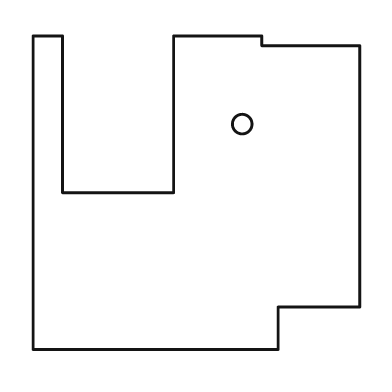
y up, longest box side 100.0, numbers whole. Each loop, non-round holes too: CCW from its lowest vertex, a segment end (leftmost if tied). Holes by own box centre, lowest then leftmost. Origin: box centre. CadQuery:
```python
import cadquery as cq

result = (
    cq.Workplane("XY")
    .moveTo(-50.0, -48.0)
    .lineTo(25.0, -48.0)
    .lineTo(25.0, -35.0)
    .lineTo(50.0, -35.0)
    .lineTo(50.0, 45.0)
    .lineTo(20.0, 45.0)
    .lineTo(20.0, 48.0)
    .lineTo(-7.0, 48.0)
    .lineTo(-7.0, 0.0)
    .lineTo(-41.0, 0.0)
    .lineTo(-41.0, 48.0)
    .lineTo(-50.0, 48.0)
    .close()
    .moveTo(14.0, 21.0)
    .circle(3.0)
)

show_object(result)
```